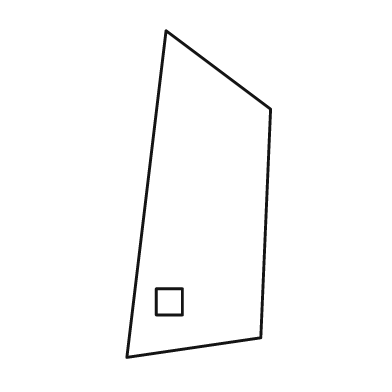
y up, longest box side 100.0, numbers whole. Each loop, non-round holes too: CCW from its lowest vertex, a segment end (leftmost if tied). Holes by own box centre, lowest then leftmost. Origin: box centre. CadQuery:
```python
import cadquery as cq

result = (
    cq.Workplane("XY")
    .moveTo(-22.0, -50.0)
    .lineTo(19.0, -44.0)
    .lineTo(22.0, 26.0)
    .lineTo(-10.0, 50.0)
    .close()
    .moveTo(-13.0, -37.0)
    .lineTo(-5.0, -37.0)
    .lineTo(-5.0, -29.0)
    .lineTo(-13.0, -29.0)
    .close()
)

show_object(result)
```